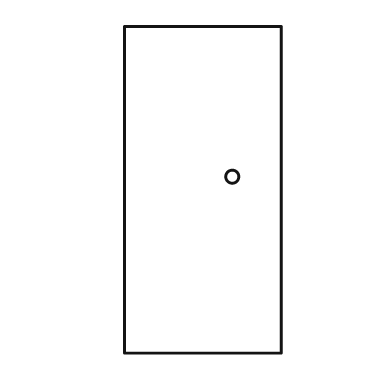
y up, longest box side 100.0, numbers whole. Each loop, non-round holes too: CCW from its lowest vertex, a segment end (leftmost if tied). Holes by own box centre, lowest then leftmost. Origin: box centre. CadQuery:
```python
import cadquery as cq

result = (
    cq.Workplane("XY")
    .moveTo(-24.0, -50.0)
    .lineTo(24.0, -50.0)
    .lineTo(24.0, 50.0)
    .lineTo(-24.0, 50.0)
    .close()
    .moveTo(9.0, 4.0)
    .circle(2.0)
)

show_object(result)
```